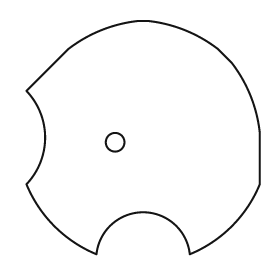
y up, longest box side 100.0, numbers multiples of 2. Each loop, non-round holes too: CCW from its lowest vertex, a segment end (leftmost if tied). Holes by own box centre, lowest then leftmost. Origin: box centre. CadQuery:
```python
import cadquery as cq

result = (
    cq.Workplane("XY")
    .moveTo(-20.0, -50.0)
    .threePointArc((0.0, -32.0), (20.0, -50.0))
    .threePointArc((38.0, -38.0), (50.0, -20.0))
    .lineTo(50.0, 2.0)
    .threePointArc((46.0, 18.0), (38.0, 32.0))
    .lineTo(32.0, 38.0)
    .threePointArc((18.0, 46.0), (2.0, 50.0))
    .lineTo(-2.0, 50.0)
    .threePointArc((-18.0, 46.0), (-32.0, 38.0))
    .lineTo(-50.0, 20.0)
    .threePointArc((-42.0, 0.0), (-50.0, -20.0))
    .threePointArc((-38.0, -38.0), (-20.0, -50.0))
    .close()
    .moveTo(-12.0, -2.0)
    .circle(4.0)
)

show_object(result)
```